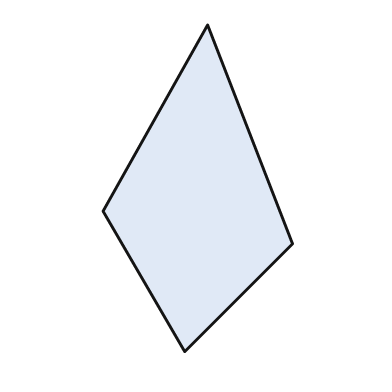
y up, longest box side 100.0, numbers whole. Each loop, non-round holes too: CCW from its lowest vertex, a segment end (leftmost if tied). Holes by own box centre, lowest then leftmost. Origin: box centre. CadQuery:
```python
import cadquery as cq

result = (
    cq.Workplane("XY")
    .moveTo(-4.0, -50.0)
    .lineTo(29.0, -17.0)
    .lineTo(3.0, 50.0)
    .lineTo(-29.0, -7.0)
    .close()
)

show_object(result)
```